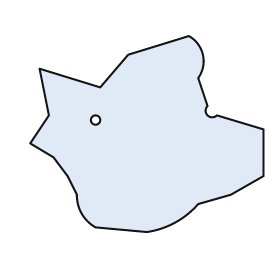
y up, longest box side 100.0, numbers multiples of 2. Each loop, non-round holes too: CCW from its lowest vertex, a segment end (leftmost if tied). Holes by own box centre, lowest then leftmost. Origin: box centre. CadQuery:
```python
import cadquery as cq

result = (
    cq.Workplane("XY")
    .moveTo(0.0, -42.0)
    .threePointArc((12.0, -38.0), (22.0, -30.0))
    .lineTo(36.0, -26.0)
    .lineTo(50.0, -18.0)
    .lineTo(50.0, 2.0)
    .lineTo(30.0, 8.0)
    .threePointArc((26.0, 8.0), (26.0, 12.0))
    .lineTo(22.0, 24.0)
    .threePointArc((24.0, 34.0), (18.0, 42.0))
    .lineTo(-8.0, 34.0)
    .lineTo(-20.0, 20.0)
    .lineTo(-46.0, 28.0)
    .lineTo(-42.0, 8.0)
    .lineTo(-50.0, -4.0)
    .lineTo(-40.0, -10.0)
    .lineTo(-34.0, -18.0)
    .lineTo(-30.0, -26.0)
    .threePointArc((-28.0, -34.0), (-22.0, -40.0))
    .close()
    .moveTo(-22.0, 6.0)
    .circle(2.0)
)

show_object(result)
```